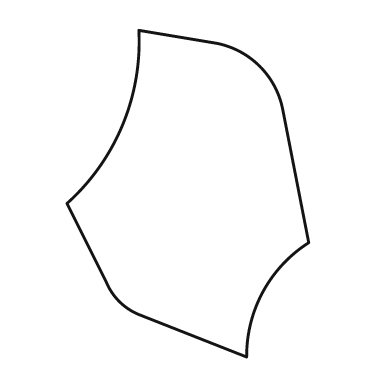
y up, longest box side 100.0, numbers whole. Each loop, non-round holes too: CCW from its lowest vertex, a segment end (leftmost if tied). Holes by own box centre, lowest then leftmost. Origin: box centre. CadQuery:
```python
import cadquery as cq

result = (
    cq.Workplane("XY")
    .moveTo(18.0, -50.0)
    .threePointArc((23.0, -30.0), (37.0, -15.0))
    .lineTo(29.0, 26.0)
    .threePointArc((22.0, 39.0), (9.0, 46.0))
    .lineTo(-15.0, 50.0)
    .threePointArc((-20.0, 21.0), (-37.0, -3.0))
    .lineTo(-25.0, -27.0)
    .threePointArc((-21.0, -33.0), (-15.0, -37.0))
    .close()
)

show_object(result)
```